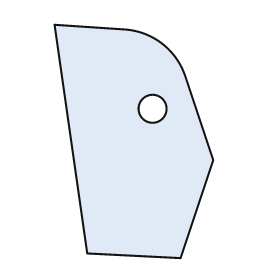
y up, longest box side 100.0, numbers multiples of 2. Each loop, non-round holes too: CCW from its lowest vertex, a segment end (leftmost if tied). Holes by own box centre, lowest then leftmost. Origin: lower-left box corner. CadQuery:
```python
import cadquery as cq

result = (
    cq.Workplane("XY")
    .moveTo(54.0, 0.0)
    .lineTo(68.0, 42.0)
    .lineTo(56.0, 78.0)
    .threePointArc((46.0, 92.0), (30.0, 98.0))
    .lineTo(0.0, 100.0)
    .lineTo(14.0, 2.0)
    .close()
    .moveTo(42.0, 64.0)
    .circle(6.0)
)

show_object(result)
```